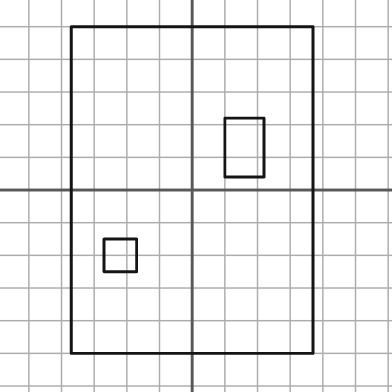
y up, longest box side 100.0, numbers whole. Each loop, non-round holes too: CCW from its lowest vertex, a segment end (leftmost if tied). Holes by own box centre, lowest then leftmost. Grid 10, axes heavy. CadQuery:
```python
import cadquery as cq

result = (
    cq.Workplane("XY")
    .moveTo(-37.0, -50.0)
    .lineTo(37.0, -50.0)
    .lineTo(37.0, 50.0)
    .lineTo(-37.0, 50.0)
    .close()
    .moveTo(-27.0, -25.0)
    .lineTo(-17.0, -25.0)
    .lineTo(-17.0, -15.0)
    .lineTo(-27.0, -15.0)
    .close()
    .moveTo(10.0, 4.0)
    .lineTo(22.0, 4.0)
    .lineTo(22.0, 22.0)
    .lineTo(10.0, 22.0)
    .close()
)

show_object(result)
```